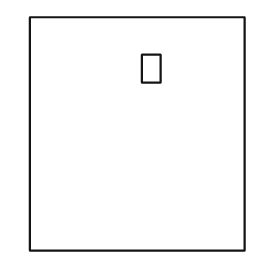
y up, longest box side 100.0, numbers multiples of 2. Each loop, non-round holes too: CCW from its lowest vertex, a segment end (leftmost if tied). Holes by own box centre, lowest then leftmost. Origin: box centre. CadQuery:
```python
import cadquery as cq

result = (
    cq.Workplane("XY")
    .moveTo(-46.0, -50.0)
    .lineTo(46.0, -50.0)
    .lineTo(46.0, 50.0)
    .lineTo(-46.0, 50.0)
    .close()
    .moveTo(2.0, 22.0)
    .lineTo(10.0, 22.0)
    .lineTo(10.0, 34.0)
    .lineTo(2.0, 34.0)
    .close()
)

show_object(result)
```